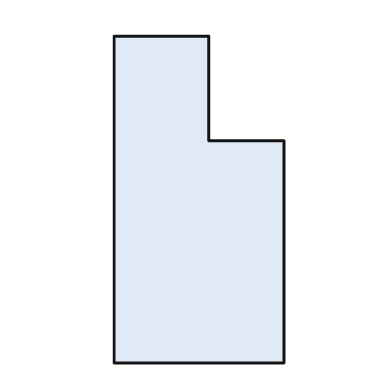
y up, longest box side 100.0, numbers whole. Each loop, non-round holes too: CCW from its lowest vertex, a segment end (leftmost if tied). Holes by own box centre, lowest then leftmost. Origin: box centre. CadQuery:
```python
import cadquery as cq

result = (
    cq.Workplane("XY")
    .moveTo(-26.0, -50.0)
    .lineTo(26.0, -50.0)
    .lineTo(26.0, 18.0)
    .lineTo(3.0, 18.0)
    .lineTo(3.0, 50.0)
    .lineTo(-26.0, 50.0)
    .close()
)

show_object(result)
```